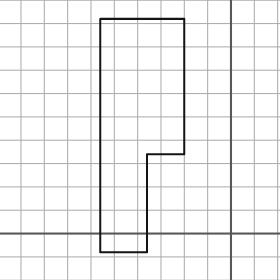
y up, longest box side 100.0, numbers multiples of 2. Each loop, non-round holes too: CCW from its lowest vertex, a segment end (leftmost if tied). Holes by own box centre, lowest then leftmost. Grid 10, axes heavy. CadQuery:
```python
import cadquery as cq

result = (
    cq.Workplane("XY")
    .moveTo(-56.0, -8.0)
    .lineTo(-36.0, -8.0)
    .lineTo(-36.0, 34.0)
    .lineTo(-20.0, 34.0)
    .lineTo(-20.0, 92.0)
    .lineTo(-56.0, 92.0)
    .close()
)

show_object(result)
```